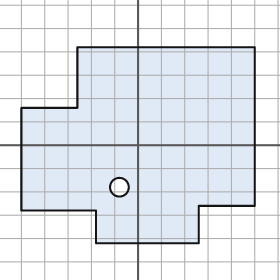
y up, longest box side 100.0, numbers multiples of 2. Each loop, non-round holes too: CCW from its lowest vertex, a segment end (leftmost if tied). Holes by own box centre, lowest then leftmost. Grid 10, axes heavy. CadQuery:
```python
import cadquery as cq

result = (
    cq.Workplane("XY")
    .moveTo(-18.0, -42.0)
    .lineTo(26.0, -42.0)
    .lineTo(26.0, -26.0)
    .lineTo(50.0, -26.0)
    .lineTo(50.0, 42.0)
    .lineTo(-26.0, 42.0)
    .lineTo(-26.0, 16.0)
    .lineTo(-50.0, 16.0)
    .lineTo(-50.0, -28.0)
    .lineTo(-18.0, -28.0)
    .close()
    .moveTo(-8.0, -18.0)
    .circle(4.0)
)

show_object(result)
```